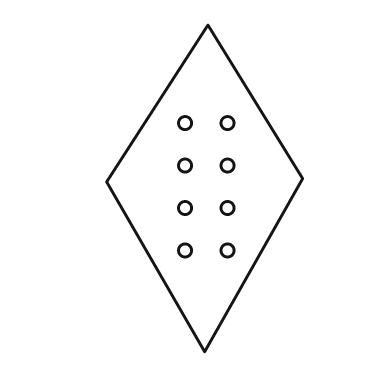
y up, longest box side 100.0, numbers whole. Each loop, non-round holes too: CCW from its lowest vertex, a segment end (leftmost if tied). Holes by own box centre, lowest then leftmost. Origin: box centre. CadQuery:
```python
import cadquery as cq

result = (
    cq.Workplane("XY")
    .moveTo(0.0, -50.0)
    .lineTo(30.0, 3.0)
    .lineTo(1.0, 50.0)
    .lineTo(-30.0, 2.0)
    .close()
    .moveTo(-6.0, -19.0)
    .circle(2.0)
    .moveTo(7.0, -19.0)
    .circle(2.0)
    .moveTo(-6.0, -6.0)
    .circle(2.0)
    .moveTo(7.0, -6.0)
    .circle(2.0)
    .moveTo(-6.0, 7.0)
    .circle(2.0)
    .moveTo(7.0, 7.0)
    .circle(2.0)
    .moveTo(-6.0, 20.0)
    .circle(2.0)
    .moveTo(7.0, 20.0)
    .circle(2.0)
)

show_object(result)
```